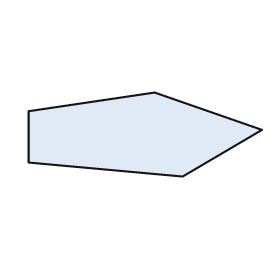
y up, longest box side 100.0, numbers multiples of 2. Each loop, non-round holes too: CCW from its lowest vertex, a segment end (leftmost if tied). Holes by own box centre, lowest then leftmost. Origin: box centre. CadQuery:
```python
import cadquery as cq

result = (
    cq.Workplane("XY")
    .moveTo(16.0, -18.0)
    .lineTo(50.0, 2.0)
    .lineTo(4.0, 18.0)
    .lineTo(-50.0, 10.0)
    .lineTo(-50.0, -12.0)
    .close()
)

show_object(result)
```